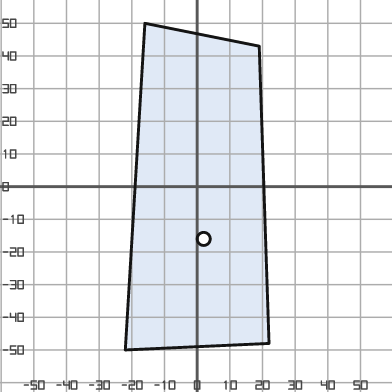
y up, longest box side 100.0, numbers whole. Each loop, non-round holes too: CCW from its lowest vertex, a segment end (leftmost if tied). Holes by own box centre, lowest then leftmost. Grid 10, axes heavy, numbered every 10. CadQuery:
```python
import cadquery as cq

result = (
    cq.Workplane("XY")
    .moveTo(-22.0, -50.0)
    .lineTo(22.0, -48.0)
    .lineTo(19.0, 43.0)
    .lineTo(-16.0, 50.0)
    .close()
    .moveTo(2.0, -16.0)
    .circle(2.0)
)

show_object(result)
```